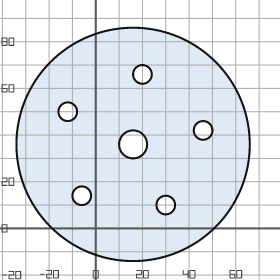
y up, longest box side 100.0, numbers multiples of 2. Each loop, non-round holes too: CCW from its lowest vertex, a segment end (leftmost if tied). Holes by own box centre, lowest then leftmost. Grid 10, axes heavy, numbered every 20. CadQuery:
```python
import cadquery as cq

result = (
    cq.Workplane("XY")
    .moveTo(16.0, 36.0)
    .circle(50.0)
    .moveTo(30.0, 10.0)
    .circle(4.0)
    .moveTo(-6.0, 14.0)
    .circle(4.0)
    .moveTo(16.0, 36.0)
    .circle(6.0)
    .moveTo(46.0, 42.0)
    .circle(4.0)
    .moveTo(-12.0, 50.0)
    .circle(4.0)
    .moveTo(20.0, 66.0)
    .circle(4.0)
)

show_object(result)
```